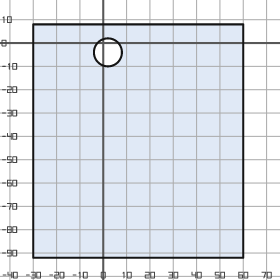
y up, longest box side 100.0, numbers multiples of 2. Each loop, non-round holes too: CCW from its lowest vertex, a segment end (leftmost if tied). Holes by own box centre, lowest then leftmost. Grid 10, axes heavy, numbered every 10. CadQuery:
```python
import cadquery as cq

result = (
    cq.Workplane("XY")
    .moveTo(-30.0, -92.0)
    .lineTo(60.0, -92.0)
    .lineTo(60.0, 8.0)
    .lineTo(-30.0, 8.0)
    .close()
    .moveTo(2.0, -4.0)
    .circle(6.0)
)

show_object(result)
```